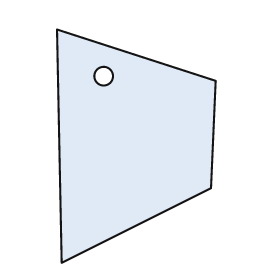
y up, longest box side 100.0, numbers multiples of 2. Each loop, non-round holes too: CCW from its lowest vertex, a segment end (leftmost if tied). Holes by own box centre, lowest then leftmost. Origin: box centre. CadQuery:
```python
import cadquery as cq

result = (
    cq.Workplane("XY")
    .moveTo(-32.0, -50.0)
    .lineTo(32.0, -18.0)
    .lineTo(34.0, 28.0)
    .lineTo(-34.0, 50.0)
    .close()
    .moveTo(-14.0, 30.0)
    .circle(4.0)
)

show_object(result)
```